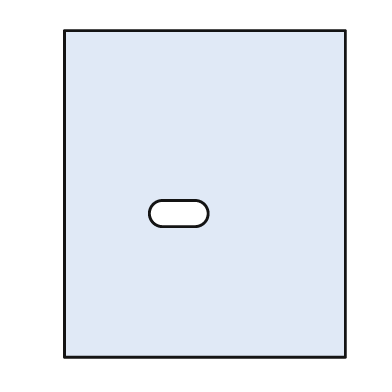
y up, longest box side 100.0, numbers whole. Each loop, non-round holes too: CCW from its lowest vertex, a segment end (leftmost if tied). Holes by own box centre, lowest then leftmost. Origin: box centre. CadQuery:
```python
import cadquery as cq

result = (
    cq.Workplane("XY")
    .moveTo(-43.0, -50.0)
    .lineTo(43.0, -50.0)
    .lineTo(43.0, 50.0)
    .lineTo(-43.0, 50.0)
    .close()
    .moveTo(-13.0, -10.0)
    .lineTo(-3.0, -10.0)
    .threePointArc((1.0, -6.0), (-3.0, -2.0))
    .lineTo(-13.0, -2.0)
    .threePointArc((-17.0, -6.0), (-13.0, -10.0))
    .close()
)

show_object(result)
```